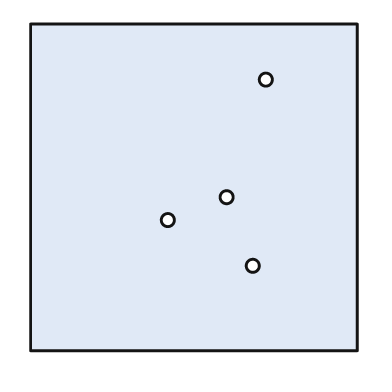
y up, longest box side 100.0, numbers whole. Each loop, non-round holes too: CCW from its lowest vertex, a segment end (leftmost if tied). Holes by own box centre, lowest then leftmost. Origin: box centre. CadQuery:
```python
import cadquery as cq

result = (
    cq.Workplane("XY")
    .moveTo(-50.0, -50.0)
    .lineTo(50.0, -50.0)
    .lineTo(50.0, 50.0)
    .lineTo(-50.0, 50.0)
    .close()
    .moveTo(18.0, -24.0)
    .circle(2.0)
    .moveTo(-8.0, -10.0)
    .circle(2.0)
    .moveTo(10.0, -3.0)
    .circle(2.0)
    .moveTo(22.0, 33.0)
    .circle(2.0)
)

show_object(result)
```